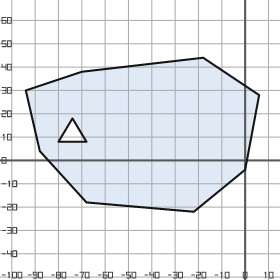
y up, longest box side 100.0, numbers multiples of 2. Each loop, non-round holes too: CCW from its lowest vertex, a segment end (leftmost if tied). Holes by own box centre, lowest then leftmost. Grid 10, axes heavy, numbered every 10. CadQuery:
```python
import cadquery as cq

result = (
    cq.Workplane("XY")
    .moveTo(-22.0, -22.0)
    .lineTo(0.0, -4.0)
    .lineTo(6.0, 28.0)
    .lineTo(-18.0, 44.0)
    .lineTo(-70.0, 38.0)
    .lineTo(-94.0, 30.0)
    .lineTo(-88.0, 4.0)
    .lineTo(-68.0, -18.0)
    .close()
    .moveTo(-80.0, 8.0)
    .lineTo(-68.0, 8.0)
    .lineTo(-74.0, 18.0)
    .close()
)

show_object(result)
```